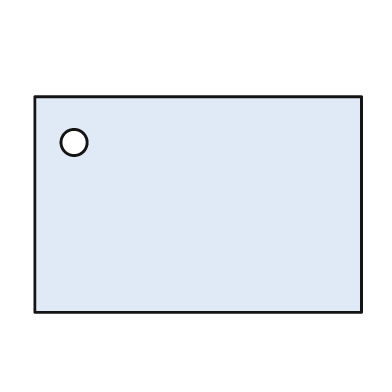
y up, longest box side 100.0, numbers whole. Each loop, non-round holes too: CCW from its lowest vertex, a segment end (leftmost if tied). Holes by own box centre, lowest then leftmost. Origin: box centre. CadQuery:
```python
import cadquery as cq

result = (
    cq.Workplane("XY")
    .moveTo(-50.0, -33.0)
    .lineTo(50.0, -33.0)
    .lineTo(50.0, 33.0)
    .lineTo(-50.0, 33.0)
    .close()
    .moveTo(-38.0, 19.0)
    .circle(4.0)
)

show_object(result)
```